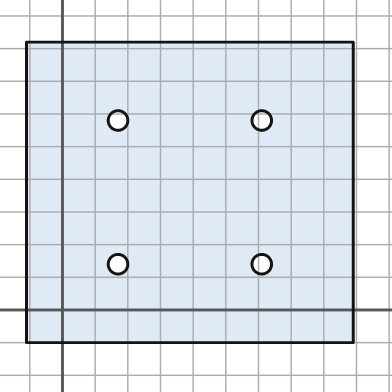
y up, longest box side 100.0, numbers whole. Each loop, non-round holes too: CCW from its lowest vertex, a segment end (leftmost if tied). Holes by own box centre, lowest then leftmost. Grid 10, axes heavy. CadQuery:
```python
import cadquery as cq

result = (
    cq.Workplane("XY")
    .moveTo(-11.0, -10.0)
    .lineTo(89.0, -10.0)
    .lineTo(89.0, 82.0)
    .lineTo(-11.0, 82.0)
    .close()
    .moveTo(17.0, 14.0)
    .circle(3.0)
    .moveTo(61.0, 14.0)
    .circle(3.0)
    .moveTo(17.0, 58.0)
    .circle(3.0)
    .moveTo(61.0, 58.0)
    .circle(3.0)
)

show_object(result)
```